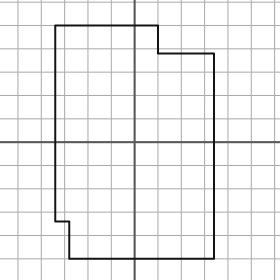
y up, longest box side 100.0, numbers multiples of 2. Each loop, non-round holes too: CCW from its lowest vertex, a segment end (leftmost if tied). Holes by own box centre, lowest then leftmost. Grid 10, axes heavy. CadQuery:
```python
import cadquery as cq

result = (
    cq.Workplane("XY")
    .moveTo(-28.0, -50.0)
    .lineTo(34.0, -50.0)
    .lineTo(34.0, 38.0)
    .lineTo(10.0, 38.0)
    .lineTo(10.0, 50.0)
    .lineTo(-34.0, 50.0)
    .lineTo(-34.0, -34.0)
    .lineTo(-28.0, -34.0)
    .close()
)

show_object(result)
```